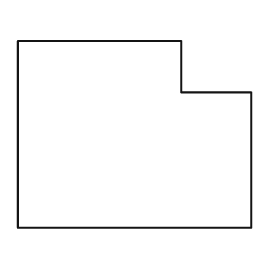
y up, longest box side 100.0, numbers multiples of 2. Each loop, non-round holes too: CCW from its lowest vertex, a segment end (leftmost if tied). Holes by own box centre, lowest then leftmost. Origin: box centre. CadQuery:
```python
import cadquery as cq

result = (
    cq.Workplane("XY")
    .moveTo(-50.0, -40.0)
    .lineTo(50.0, -40.0)
    .lineTo(50.0, 18.0)
    .lineTo(20.0, 18.0)
    .lineTo(20.0, 40.0)
    .lineTo(-50.0, 40.0)
    .close()
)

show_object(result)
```